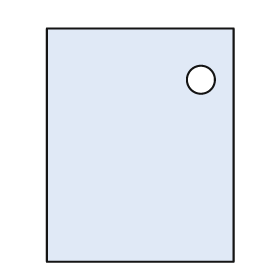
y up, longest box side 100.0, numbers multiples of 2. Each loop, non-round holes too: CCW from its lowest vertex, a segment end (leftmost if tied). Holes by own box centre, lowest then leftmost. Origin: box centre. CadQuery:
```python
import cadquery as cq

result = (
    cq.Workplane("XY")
    .moveTo(-40.0, -50.0)
    .lineTo(40.0, -50.0)
    .lineTo(40.0, 50.0)
    .lineTo(-40.0, 50.0)
    .close()
    .moveTo(26.0, 28.0)
    .circle(6.0)
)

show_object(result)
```